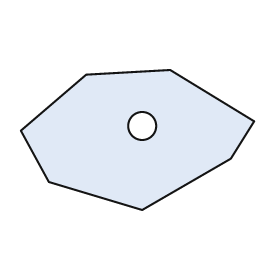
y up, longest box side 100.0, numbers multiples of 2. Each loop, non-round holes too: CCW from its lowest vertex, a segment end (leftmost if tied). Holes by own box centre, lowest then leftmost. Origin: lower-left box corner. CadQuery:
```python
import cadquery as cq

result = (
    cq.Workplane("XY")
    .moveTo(52.0, 0.0)
    .lineTo(90.0, 22.0)
    .lineTo(100.0, 38.0)
    .lineTo(64.0, 60.0)
    .lineTo(28.0, 58.0)
    .lineTo(0.0, 34.0)
    .lineTo(12.0, 12.0)
    .close()
    .moveTo(52.0, 36.0)
    .circle(6.0)
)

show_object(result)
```